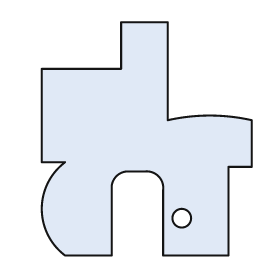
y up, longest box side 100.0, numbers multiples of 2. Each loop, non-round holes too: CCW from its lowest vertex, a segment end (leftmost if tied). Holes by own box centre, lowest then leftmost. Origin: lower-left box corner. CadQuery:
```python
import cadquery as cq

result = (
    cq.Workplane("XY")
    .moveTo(10.0, 0.0)
    .lineTo(30.0, 0.0)
    .lineTo(30.0, 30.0)
    .threePointArc((32.0, 34.0), (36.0, 36.0))
    .lineTo(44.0, 36.0)
    .threePointArc((50.0, 34.0), (52.0, 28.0))
    .lineTo(52.0, 0.0)
    .lineTo(80.0, 0.0)
    .lineTo(80.0, 38.0)
    .lineTo(90.0, 38.0)
    .lineTo(90.0, 58.0)
    .threePointArc((72.0, 60.0), (54.0, 58.0))
    .lineTo(54.0, 100.0)
    .lineTo(34.0, 100.0)
    .lineTo(34.0, 80.0)
    .lineTo(0.0, 80.0)
    .lineTo(0.0, 40.0)
    .lineTo(10.0, 40.0)
    .threePointArc((0.0, 20.0), (10.0, 0.0))
    .close()
    .moveTo(60.0, 16.0)
    .circle(4.0)
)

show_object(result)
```